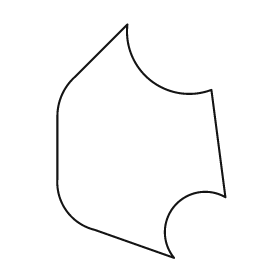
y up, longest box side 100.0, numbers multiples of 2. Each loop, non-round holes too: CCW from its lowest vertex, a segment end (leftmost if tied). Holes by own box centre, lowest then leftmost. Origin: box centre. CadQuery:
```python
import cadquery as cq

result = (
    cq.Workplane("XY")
    .moveTo(14.0, -50.0)
    .threePointArc((14.0, -28.0), (36.0, -24.0))
    .lineTo(30.0, 22.0)
    .threePointArc((4.0, 26.0), (-6.0, 50.0))
    .lineTo(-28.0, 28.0)
    .threePointArc((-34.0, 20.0), (-36.0, 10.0))
    .lineTo(-36.0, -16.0)
    .threePointArc((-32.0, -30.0), (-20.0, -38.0))
    .close()
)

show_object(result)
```